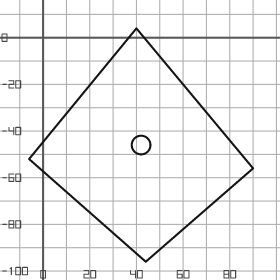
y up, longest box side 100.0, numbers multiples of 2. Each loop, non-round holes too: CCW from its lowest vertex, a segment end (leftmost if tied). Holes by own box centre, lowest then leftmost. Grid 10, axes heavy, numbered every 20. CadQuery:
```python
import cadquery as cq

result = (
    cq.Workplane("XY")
    .moveTo(44.0, -96.0)
    .lineTo(90.0, -56.0)
    .lineTo(40.0, 4.0)
    .lineTo(-6.0, -52.0)
    .close()
    .moveTo(42.0, -46.0)
    .circle(4.0)
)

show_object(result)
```